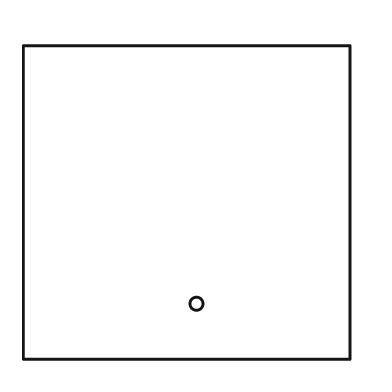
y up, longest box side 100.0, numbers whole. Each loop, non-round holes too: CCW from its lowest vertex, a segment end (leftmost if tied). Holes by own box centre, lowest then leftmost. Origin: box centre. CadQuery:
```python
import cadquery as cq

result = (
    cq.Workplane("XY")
    .moveTo(-50.0, -48.0)
    .lineTo(50.0, -48.0)
    .lineTo(50.0, 48.0)
    .lineTo(-50.0, 48.0)
    .close()
    .moveTo(3.0, -31.0)
    .circle(2.0)
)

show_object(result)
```